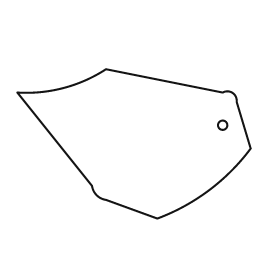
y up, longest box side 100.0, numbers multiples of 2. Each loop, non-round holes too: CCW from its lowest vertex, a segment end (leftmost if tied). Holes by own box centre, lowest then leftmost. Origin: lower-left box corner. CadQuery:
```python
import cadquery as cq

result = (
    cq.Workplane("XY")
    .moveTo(60.0, 0.0)
    .threePointArc((82.0, 12.0), (100.0, 30.0))
    .lineTo(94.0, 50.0)
    .threePointArc((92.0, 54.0), (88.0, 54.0))
    .lineTo(38.0, 64.0)
    .threePointArc((20.0, 56.0), (0.0, 54.0))
    .lineTo(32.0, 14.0)
    .threePointArc((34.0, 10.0), (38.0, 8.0))
    .close()
    .moveTo(88.0, 40.0)
    .circle(2.0)
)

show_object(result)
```